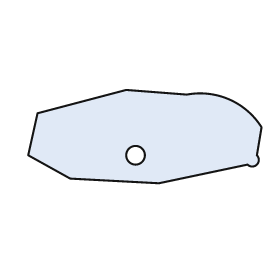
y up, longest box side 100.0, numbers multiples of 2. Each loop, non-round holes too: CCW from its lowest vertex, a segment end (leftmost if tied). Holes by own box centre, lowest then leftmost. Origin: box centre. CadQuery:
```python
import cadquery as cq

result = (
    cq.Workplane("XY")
    .moveTo(6.0, -20.0)
    .lineTo(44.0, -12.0)
    .threePointArc((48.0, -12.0), (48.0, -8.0))
    .lineTo(50.0, 4.0)
    .threePointArc((36.0, 16.0), (18.0, 18.0))
    .lineTo(-8.0, 20.0)
    .lineTo(-46.0, 10.0)
    .lineTo(-50.0, -8.0)
    .lineTo(-32.0, -18.0)
    .close()
    .moveTo(-4.0, -8.0)
    .circle(4.0)
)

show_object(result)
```